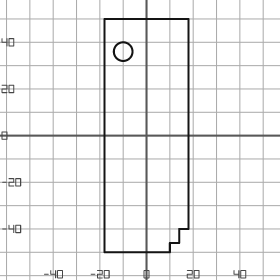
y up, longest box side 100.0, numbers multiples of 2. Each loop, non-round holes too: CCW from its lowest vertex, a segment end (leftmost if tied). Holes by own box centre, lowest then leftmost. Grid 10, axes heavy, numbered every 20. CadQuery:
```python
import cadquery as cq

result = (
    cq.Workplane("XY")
    .moveTo(-18.0, -50.0)
    .lineTo(10.0, -50.0)
    .lineTo(10.0, -46.0)
    .lineTo(14.0, -46.0)
    .lineTo(14.0, -40.0)
    .lineTo(18.0, -40.0)
    .lineTo(18.0, 50.0)
    .lineTo(-18.0, 50.0)
    .close()
    .moveTo(-10.0, 36.0)
    .circle(4.0)
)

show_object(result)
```